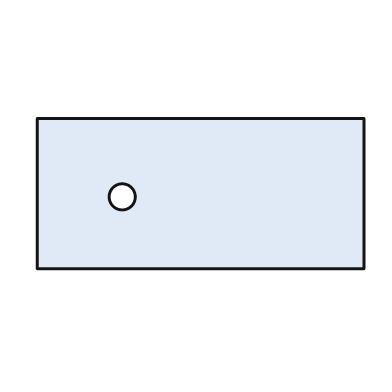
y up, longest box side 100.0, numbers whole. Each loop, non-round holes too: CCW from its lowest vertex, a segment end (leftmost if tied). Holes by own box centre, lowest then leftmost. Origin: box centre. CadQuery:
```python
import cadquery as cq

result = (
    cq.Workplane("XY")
    .moveTo(-50.0, -23.0)
    .lineTo(50.0, -23.0)
    .lineTo(50.0, 23.0)
    .lineTo(-50.0, 23.0)
    .close()
    .moveTo(-24.0, -1.0)
    .circle(4.0)
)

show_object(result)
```